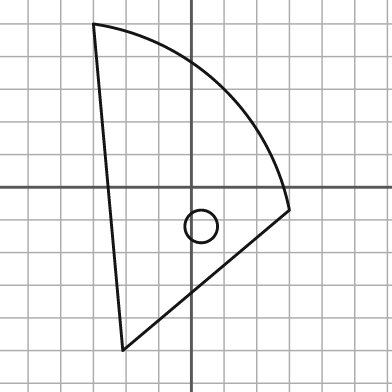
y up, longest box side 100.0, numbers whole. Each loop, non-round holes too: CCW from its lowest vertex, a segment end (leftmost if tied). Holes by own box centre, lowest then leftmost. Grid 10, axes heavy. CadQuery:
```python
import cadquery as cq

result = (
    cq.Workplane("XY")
    .moveTo(-21.0, -50.0)
    .lineTo(30.0, -7.0)
    .threePointArc((9.0, 31.0), (-30.0, 50.0))
    .close()
    .moveTo(3.0, -12.0)
    .circle(5.0)
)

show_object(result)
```